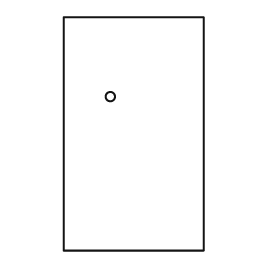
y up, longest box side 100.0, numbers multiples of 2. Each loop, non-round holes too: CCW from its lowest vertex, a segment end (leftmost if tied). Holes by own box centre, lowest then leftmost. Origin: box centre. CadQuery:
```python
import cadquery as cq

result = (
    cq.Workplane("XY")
    .moveTo(-30.0, -50.0)
    .lineTo(30.0, -50.0)
    .lineTo(30.0, 50.0)
    .lineTo(-30.0, 50.0)
    .close()
    .moveTo(-10.0, 16.0)
    .circle(2.0)
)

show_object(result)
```